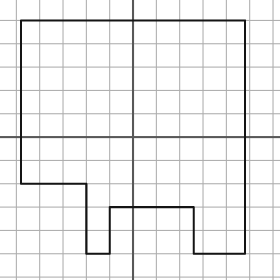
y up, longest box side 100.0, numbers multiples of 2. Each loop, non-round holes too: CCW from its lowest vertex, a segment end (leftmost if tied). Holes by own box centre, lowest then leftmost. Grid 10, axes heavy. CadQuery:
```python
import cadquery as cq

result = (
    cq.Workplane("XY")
    .moveTo(-20.0, -50.0)
    .lineTo(-10.0, -50.0)
    .lineTo(-10.0, -30.0)
    .lineTo(26.0, -30.0)
    .lineTo(26.0, -50.0)
    .lineTo(48.0, -50.0)
    .lineTo(48.0, 50.0)
    .lineTo(-48.0, 50.0)
    .lineTo(-48.0, -20.0)
    .lineTo(-20.0, -20.0)
    .close()
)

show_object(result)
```